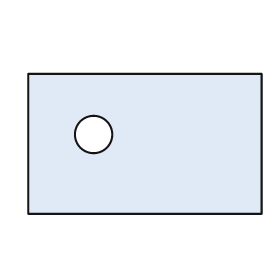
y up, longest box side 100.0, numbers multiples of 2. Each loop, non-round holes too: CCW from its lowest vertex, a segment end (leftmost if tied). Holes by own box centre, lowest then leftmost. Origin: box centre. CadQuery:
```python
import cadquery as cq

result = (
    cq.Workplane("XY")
    .moveTo(-50.0, -30.0)
    .lineTo(50.0, -30.0)
    .lineTo(50.0, 30.0)
    .lineTo(-50.0, 30.0)
    .close()
    .moveTo(-22.0, 4.0)
    .circle(8.0)
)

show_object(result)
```